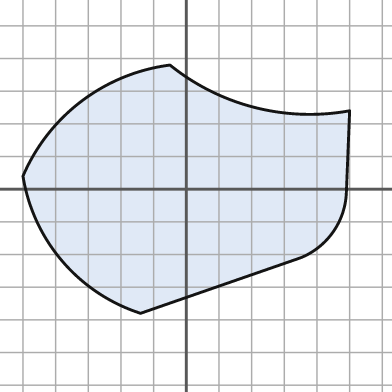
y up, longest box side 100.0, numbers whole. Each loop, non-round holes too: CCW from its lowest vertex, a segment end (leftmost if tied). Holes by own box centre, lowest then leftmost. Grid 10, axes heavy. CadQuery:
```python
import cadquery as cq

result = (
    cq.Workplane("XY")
    .moveTo(-14.0, -38.0)
    .lineTo(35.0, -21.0)
    .threePointArc((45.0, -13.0), (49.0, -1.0))
    .lineTo(50.0, 24.0)
    .threePointArc((21.0, 25.0), (-5.0, 38.0))
    .threePointArc((-32.0, 27.0), (-50.0, 4.0))
    .threePointArc((-38.0, -22.0), (-14.0, -38.0))
    .close()
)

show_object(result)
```